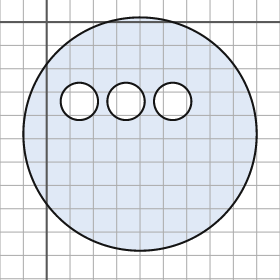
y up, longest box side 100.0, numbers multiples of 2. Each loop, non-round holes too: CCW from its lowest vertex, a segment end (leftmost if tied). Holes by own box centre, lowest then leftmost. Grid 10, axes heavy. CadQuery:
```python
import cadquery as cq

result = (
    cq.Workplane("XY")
    .moveTo(40.0, -48.0)
    .circle(50.0)
    .moveTo(14.0, -34.0)
    .circle(8.0)
    .moveTo(34.0, -34.0)
    .circle(8.0)
    .moveTo(54.0, -34.0)
    .circle(8.0)
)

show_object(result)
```